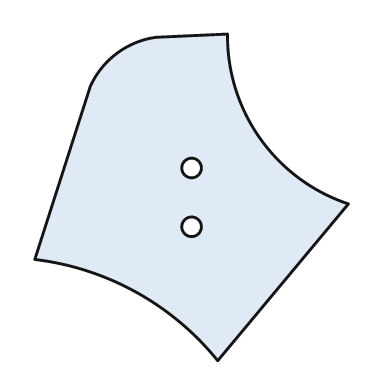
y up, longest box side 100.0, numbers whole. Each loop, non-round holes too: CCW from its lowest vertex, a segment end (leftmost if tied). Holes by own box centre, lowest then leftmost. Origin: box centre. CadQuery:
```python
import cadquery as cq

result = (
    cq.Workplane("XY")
    .moveTo(8.0, -50.0)
    .lineTo(48.0, -2.0)
    .threePointArc((21.0, 18.0), (11.0, 50.0))
    .lineTo(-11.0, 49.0)
    .threePointArc((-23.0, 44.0), (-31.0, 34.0))
    .lineTo(-48.0, -19.0)
    .threePointArc((-17.0, -29.0), (8.0, -50.0))
    .close()
    .moveTo(0.0, -9.0)
    .circle(3.0)
    .moveTo(0.0, 9.0)
    .circle(3.0)
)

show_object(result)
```